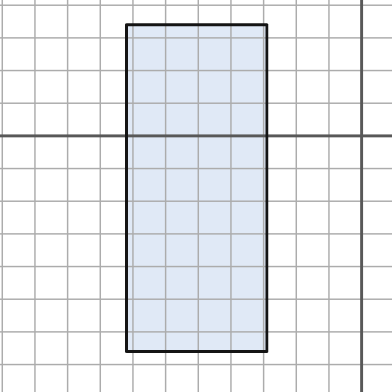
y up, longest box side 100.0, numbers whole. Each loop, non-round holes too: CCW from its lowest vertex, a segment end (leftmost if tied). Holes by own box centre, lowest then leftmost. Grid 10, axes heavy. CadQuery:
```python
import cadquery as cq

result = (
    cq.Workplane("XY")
    .moveTo(-72.0, -66.0)
    .lineTo(-29.0, -66.0)
    .lineTo(-29.0, 34.0)
    .lineTo(-72.0, 34.0)
    .close()
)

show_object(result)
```